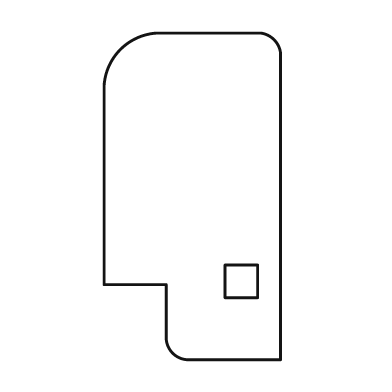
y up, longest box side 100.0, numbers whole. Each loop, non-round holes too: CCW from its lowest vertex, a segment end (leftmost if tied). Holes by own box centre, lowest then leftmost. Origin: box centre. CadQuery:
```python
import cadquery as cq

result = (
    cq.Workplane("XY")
    .moveTo(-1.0, -50.0)
    .lineTo(27.0, -50.0)
    .lineTo(27.0, 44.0)
    .threePointArc((25.0, 48.0), (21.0, 50.0))
    .lineTo(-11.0, 50.0)
    .threePointArc((-22.0, 45.0), (-27.0, 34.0))
    .lineTo(-27.0, -27.0)
    .lineTo(-8.0, -27.0)
    .lineTo(-8.0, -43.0)
    .threePointArc((-6.0, -48.0), (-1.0, -50.0))
    .close()
    .moveTo(10.0, -31.0)
    .lineTo(20.0, -31.0)
    .lineTo(20.0, -21.0)
    .lineTo(10.0, -21.0)
    .close()
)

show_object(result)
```